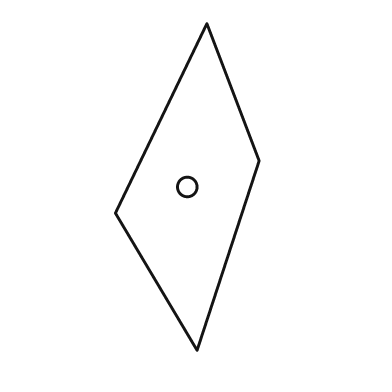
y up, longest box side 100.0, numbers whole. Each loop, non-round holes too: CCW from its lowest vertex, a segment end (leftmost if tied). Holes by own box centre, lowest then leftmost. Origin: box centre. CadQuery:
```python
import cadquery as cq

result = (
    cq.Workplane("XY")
    .moveTo(3.0, -50.0)
    .lineTo(22.0, 8.0)
    .lineTo(6.0, 50.0)
    .lineTo(-22.0, -8.0)
    .close()
    .moveTo(0.0, 0.0)
    .circle(3.0)
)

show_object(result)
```